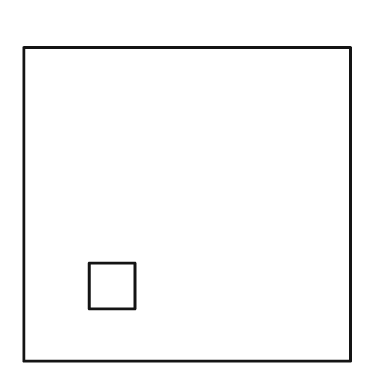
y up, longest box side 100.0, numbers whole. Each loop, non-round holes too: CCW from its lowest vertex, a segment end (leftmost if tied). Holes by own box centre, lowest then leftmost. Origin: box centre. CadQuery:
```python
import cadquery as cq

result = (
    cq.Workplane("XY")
    .moveTo(-50.0, -48.0)
    .lineTo(50.0, -48.0)
    .lineTo(50.0, 48.0)
    .lineTo(-50.0, 48.0)
    .close()
    .moveTo(-30.0, -32.0)
    .lineTo(-16.0, -32.0)
    .lineTo(-16.0, -18.0)
    .lineTo(-30.0, -18.0)
    .close()
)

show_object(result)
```